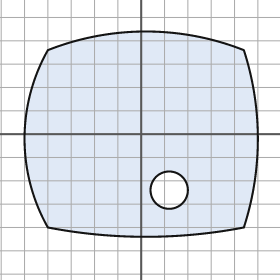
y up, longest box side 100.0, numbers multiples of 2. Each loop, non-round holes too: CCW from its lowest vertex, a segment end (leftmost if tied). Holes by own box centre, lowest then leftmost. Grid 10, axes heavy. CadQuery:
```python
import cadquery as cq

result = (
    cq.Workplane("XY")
    .moveTo(-40.0, -40.0)
    .threePointArc((2.0, -44.0), (44.0, -40.0))
    .threePointArc((50.0, -2.0), (44.0, 36.0))
    .threePointArc((2.0, 44.0), (-40.0, 36.0))
    .threePointArc((-50.0, -2.0), (-40.0, -40.0))
    .close()
    .moveTo(12.0, -24.0)
    .circle(8.0)
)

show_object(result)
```